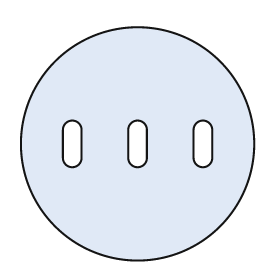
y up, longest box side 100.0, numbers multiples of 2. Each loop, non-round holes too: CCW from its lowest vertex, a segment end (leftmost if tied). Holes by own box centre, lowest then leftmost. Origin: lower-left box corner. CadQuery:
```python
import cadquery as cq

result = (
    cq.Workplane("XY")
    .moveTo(50.0, 50.0)
    .circle(50.0)
    .moveTo(18.0, 44.0)
    .threePointArc((22.0, 40.0), (26.0, 44.0))
    .lineTo(26.0, 56.0)
    .threePointArc((22.0, 60.0), (18.0, 56.0))
    .close()
    .moveTo(46.0, 44.0)
    .threePointArc((50.0, 40.0), (54.0, 44.0))
    .lineTo(54.0, 56.0)
    .threePointArc((50.0, 60.0), (46.0, 56.0))
    .close()
    .moveTo(74.0, 44.0)
    .threePointArc((78.0, 40.0), (82.0, 44.0))
    .lineTo(82.0, 56.0)
    .threePointArc((78.0, 60.0), (74.0, 56.0))
    .close()
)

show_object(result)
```